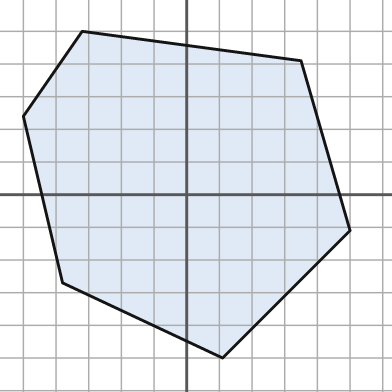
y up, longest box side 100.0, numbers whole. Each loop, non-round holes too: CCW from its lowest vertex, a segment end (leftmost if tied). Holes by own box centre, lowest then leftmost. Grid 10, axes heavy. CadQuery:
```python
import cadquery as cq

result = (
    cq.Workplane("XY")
    .moveTo(11.0, -50.0)
    .lineTo(50.0, -11.0)
    .lineTo(35.0, 41.0)
    .lineTo(-32.0, 50.0)
    .lineTo(-50.0, 24.0)
    .lineTo(-38.0, -27.0)
    .close()
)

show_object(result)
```